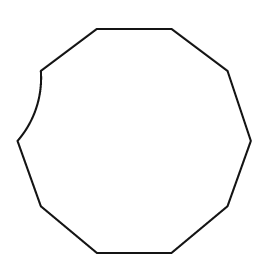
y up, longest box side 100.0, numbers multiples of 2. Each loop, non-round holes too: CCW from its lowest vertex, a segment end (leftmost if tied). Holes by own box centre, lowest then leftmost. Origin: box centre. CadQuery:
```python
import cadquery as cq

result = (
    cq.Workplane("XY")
    .moveTo(-16.0, -48.0)
    .lineTo(16.0, -48.0)
    .lineTo(40.0, -28.0)
    .lineTo(50.0, 0.0)
    .lineTo(40.0, 30.0)
    .lineTo(16.0, 48.0)
    .lineTo(-16.0, 48.0)
    .lineTo(-40.0, 30.0)
    .threePointArc((-42.0, 14.0), (-50.0, 0.0))
    .lineTo(-40.0, -28.0)
    .close()
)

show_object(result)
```